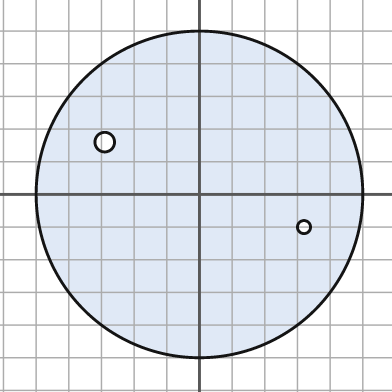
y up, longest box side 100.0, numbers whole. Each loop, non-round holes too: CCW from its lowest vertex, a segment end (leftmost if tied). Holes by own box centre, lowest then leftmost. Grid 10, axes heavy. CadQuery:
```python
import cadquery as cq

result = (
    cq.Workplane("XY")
    .moveTo(0.0, 0.0)
    .circle(50.0)
    .moveTo(32.0, -10.0)
    .circle(2.0)
    .moveTo(-29.0, 16.0)
    .circle(3.0)
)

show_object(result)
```